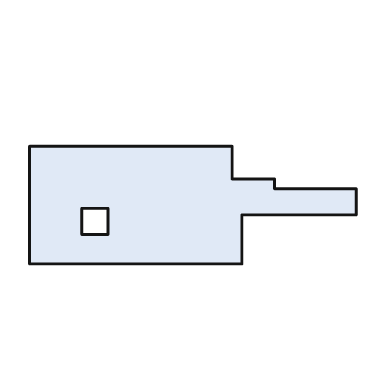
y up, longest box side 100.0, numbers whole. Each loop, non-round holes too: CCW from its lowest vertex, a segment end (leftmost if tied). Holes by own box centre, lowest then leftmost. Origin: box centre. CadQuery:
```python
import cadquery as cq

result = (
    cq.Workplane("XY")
    .moveTo(-50.0, -18.0)
    .lineTo(15.0, -18.0)
    .lineTo(15.0, -3.0)
    .lineTo(50.0, -3.0)
    .lineTo(50.0, 5.0)
    .lineTo(25.0, 5.0)
    .lineTo(25.0, 8.0)
    .lineTo(12.0, 8.0)
    .lineTo(12.0, 18.0)
    .lineTo(-50.0, 18.0)
    .close()
    .moveTo(-34.0, -9.0)
    .lineTo(-26.0, -9.0)
    .lineTo(-26.0, -1.0)
    .lineTo(-34.0, -1.0)
    .close()
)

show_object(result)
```